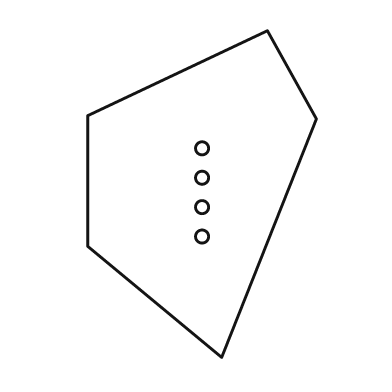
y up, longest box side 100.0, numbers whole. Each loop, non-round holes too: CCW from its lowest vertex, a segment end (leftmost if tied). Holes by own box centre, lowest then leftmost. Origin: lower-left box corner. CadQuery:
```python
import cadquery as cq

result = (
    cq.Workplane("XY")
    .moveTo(41.0, 0.0)
    .lineTo(70.0, 73.0)
    .lineTo(55.0, 100.0)
    .lineTo(0.0, 74.0)
    .lineTo(0.0, 34.0)
    .close()
    .moveTo(35.0, 37.0)
    .circle(2.0)
    .moveTo(35.0, 46.0)
    .circle(2.0)
    .moveTo(35.0, 55.0)
    .circle(2.0)
    .moveTo(35.0, 64.0)
    .circle(2.0)
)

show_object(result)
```